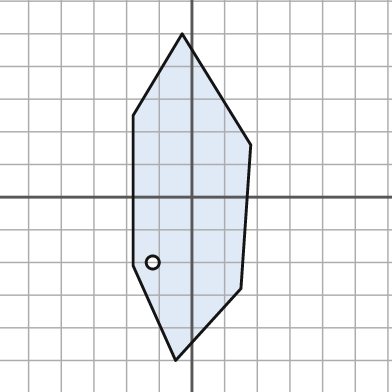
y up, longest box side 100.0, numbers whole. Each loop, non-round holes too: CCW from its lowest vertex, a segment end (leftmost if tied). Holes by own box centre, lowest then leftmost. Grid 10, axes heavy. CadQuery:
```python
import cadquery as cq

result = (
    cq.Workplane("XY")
    .moveTo(-5.0, -50.0)
    .lineTo(15.0, -28.0)
    .lineTo(18.0, 16.0)
    .lineTo(-3.0, 50.0)
    .lineTo(-18.0, 25.0)
    .lineTo(-18.0, -21.0)
    .close()
    .moveTo(-12.0, -20.0)
    .circle(2.0)
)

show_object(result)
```